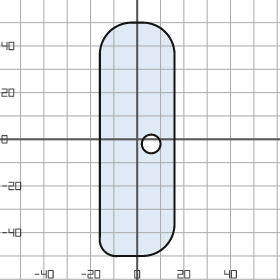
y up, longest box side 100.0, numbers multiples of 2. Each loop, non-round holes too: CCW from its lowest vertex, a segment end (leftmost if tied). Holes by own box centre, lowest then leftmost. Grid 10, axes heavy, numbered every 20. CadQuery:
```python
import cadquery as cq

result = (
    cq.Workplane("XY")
    .moveTo(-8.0, -50.0)
    .lineTo(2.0, -50.0)
    .threePointArc((12.0, -46.0), (16.0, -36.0))
    .lineTo(16.0, 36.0)
    .threePointArc((12.0, 46.0), (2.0, 50.0))
    .lineTo(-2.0, 50.0)
    .threePointArc((-12.0, 46.0), (-16.0, 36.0))
    .lineTo(-16.0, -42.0)
    .threePointArc((-14.0, -48.0), (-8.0, -50.0))
    .close()
    .moveTo(6.0, -2.0)
    .circle(4.0)
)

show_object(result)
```